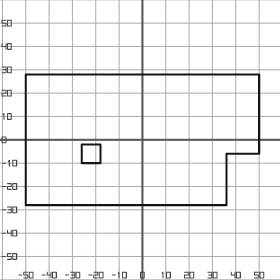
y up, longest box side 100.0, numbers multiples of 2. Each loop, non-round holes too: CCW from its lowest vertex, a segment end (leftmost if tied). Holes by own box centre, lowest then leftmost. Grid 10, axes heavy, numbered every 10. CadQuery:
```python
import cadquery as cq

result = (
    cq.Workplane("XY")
    .moveTo(-50.0, -28.0)
    .lineTo(36.0, -28.0)
    .lineTo(36.0, -6.0)
    .lineTo(50.0, -6.0)
    .lineTo(50.0, 28.0)
    .lineTo(-50.0, 28.0)
    .close()
    .moveTo(-26.0, -10.0)
    .lineTo(-18.0, -10.0)
    .lineTo(-18.0, -2.0)
    .lineTo(-26.0, -2.0)
    .close()
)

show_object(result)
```